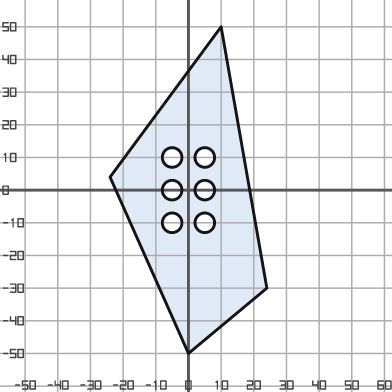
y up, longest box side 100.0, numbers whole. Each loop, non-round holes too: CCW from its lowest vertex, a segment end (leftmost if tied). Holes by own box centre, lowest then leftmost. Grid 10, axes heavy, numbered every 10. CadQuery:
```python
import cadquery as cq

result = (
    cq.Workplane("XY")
    .moveTo(0.0, -50.0)
    .lineTo(24.0, -30.0)
    .lineTo(10.0, 50.0)
    .lineTo(-24.0, 4.0)
    .close()
    .moveTo(-5.0, -10.0)
    .circle(3.0)
    .moveTo(5.0, -10.0)
    .circle(3.0)
    .moveTo(-5.0, 0.0)
    .circle(3.0)
    .moveTo(5.0, 0.0)
    .circle(3.0)
    .moveTo(-5.0, 10.0)
    .circle(3.0)
    .moveTo(5.0, 10.0)
    .circle(3.0)
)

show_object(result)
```